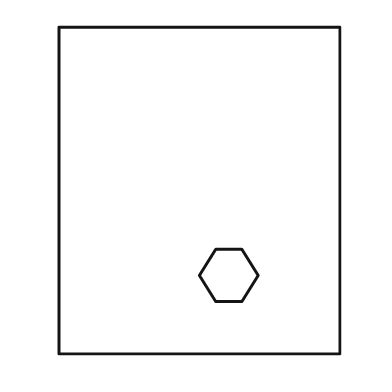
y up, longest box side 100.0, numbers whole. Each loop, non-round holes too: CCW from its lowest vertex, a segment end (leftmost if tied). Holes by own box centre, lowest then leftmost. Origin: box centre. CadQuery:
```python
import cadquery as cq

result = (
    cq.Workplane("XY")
    .moveTo(-43.0, -50.0)
    .lineTo(43.0, -50.0)
    .lineTo(43.0, 50.0)
    .lineTo(-43.0, 50.0)
    .close()
    .moveTo(5.0, -34.0)
    .lineTo(13.0, -34.0)
    .lineTo(18.0, -26.0)
    .lineTo(13.0, -18.0)
    .lineTo(5.0, -18.0)
    .lineTo(0.0, -26.0)
    .close()
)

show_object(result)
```